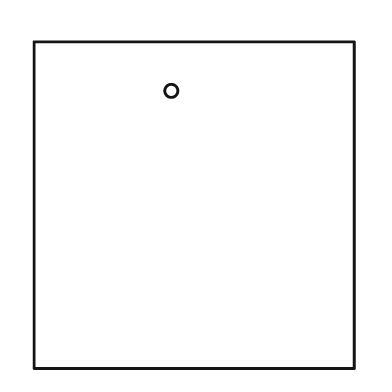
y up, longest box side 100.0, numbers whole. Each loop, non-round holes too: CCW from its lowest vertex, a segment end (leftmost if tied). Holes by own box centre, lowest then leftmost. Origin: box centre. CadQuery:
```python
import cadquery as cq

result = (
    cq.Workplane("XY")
    .moveTo(-49.0, -50.0)
    .lineTo(49.0, -50.0)
    .lineTo(49.0, 50.0)
    .lineTo(-49.0, 50.0)
    .close()
    .moveTo(-7.0, 35.0)
    .circle(2.0)
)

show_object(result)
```